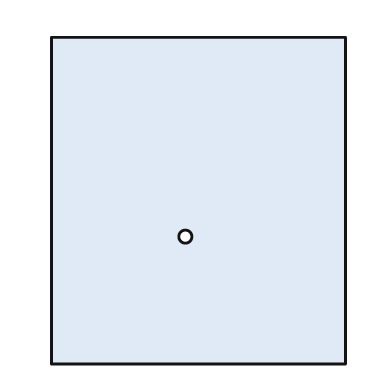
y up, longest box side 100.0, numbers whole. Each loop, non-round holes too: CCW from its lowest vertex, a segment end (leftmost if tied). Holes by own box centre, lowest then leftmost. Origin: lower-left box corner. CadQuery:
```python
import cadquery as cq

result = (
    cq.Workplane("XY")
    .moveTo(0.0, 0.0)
    .lineTo(90.0, 0.0)
    .lineTo(90.0, 100.0)
    .lineTo(0.0, 100.0)
    .close()
    .moveTo(41.0, 39.0)
    .circle(2.0)
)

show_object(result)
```